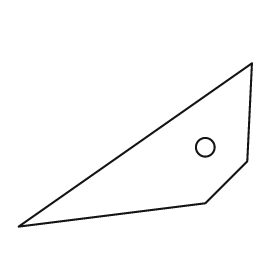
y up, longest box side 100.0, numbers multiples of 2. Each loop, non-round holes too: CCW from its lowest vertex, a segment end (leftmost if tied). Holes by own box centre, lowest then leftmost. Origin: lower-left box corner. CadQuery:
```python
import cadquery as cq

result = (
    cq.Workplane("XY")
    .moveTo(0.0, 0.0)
    .lineTo(80.0, 10.0)
    .lineTo(98.0, 28.0)
    .lineTo(100.0, 70.0)
    .close()
    .moveTo(80.0, 34.0)
    .circle(4.0)
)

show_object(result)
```